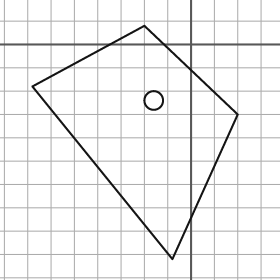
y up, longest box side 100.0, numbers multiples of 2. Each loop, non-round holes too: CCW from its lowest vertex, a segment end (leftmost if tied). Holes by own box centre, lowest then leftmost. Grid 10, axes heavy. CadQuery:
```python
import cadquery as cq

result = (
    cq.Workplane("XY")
    .moveTo(-8.0, -92.0)
    .lineTo(20.0, -30.0)
    .lineTo(-20.0, 8.0)
    .lineTo(-68.0, -18.0)
    .close()
    .moveTo(-16.0, -24.0)
    .circle(4.0)
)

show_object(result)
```